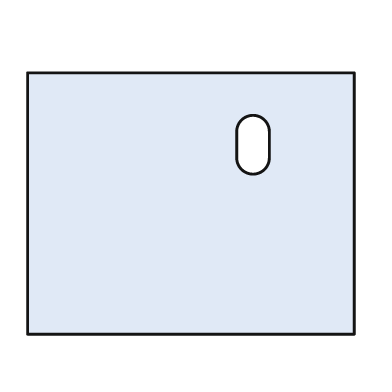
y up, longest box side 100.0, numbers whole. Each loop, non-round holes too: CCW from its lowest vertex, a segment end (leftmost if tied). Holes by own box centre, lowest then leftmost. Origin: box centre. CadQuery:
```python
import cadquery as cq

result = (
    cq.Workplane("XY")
    .moveTo(-50.0, -40.0)
    .lineTo(50.0, -40.0)
    .lineTo(50.0, 40.0)
    .lineTo(-50.0, 40.0)
    .close()
    .moveTo(14.0, 14.0)
    .threePointArc((19.0, 9.0), (24.0, 14.0))
    .lineTo(24.0, 22.0)
    .threePointArc((19.0, 27.0), (14.0, 22.0))
    .close()
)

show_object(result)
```